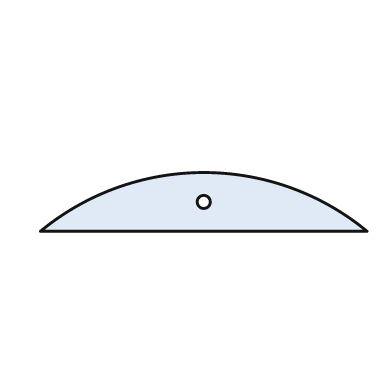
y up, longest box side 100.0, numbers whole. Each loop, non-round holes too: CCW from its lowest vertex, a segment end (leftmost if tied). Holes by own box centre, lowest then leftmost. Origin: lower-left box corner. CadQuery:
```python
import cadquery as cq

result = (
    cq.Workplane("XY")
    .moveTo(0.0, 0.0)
    .lineTo(100.0, 0.0)
    .threePointArc((50.0, 18.0), (0.0, 0.0))
    .close()
    .moveTo(50.0, 9.0)
    .circle(2.0)
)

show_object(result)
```